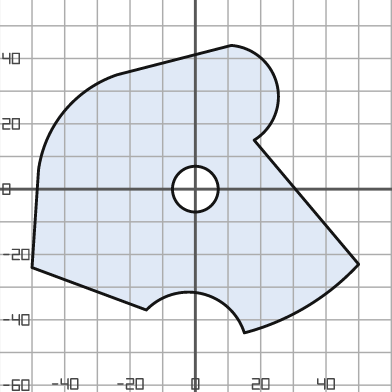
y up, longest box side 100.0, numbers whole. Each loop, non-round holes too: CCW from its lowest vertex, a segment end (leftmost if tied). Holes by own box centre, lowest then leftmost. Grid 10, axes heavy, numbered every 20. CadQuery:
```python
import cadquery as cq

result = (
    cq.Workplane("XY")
    .moveTo(15.0, -44.0)
    .threePointArc((34.0, -36.0), (50.0, -23.0))
    .lineTo(18.0, 15.0)
    .threePointArc((25.0, 32.0), (11.0, 44.0))
    .lineTo(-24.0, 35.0)
    .threePointArc((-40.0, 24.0), (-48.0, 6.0))
    .lineTo(-50.0, -24.0)
    .lineTo(-15.0, -37.0)
    .threePointArc((2.0, -32.0), (15.0, -44.0))
    .close()
    .moveTo(0.0, 0.0)
    .circle(7.0)
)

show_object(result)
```